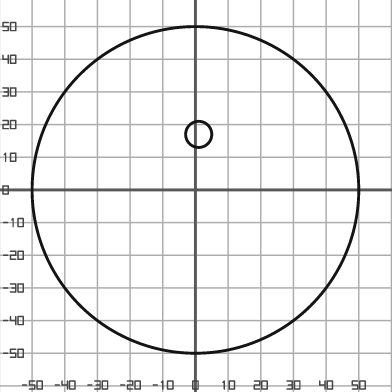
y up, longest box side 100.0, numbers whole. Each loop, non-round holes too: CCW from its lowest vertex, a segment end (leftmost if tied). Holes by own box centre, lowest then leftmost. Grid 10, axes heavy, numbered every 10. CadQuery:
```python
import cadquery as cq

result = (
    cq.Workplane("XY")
    .moveTo(0.0, 0.0)
    .circle(50.0)
    .moveTo(1.0, 17.0)
    .circle(4.0)
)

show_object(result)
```